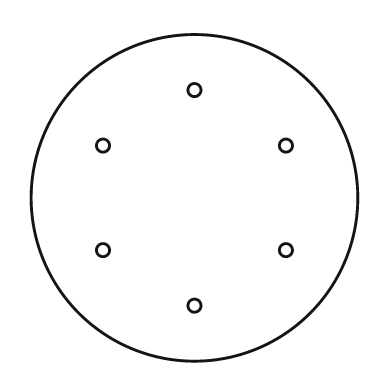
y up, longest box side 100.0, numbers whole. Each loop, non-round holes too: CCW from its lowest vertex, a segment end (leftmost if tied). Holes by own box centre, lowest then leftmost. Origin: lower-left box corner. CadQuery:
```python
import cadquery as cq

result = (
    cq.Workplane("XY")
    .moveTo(50.0, 50.0)
    .circle(50.0)
    .moveTo(50.0, 17.0)
    .circle(2.0)
    .moveTo(22.0, 34.0)
    .circle(2.0)
    .moveTo(78.0, 34.0)
    .circle(2.0)
    .moveTo(22.0, 66.0)
    .circle(2.0)
    .moveTo(78.0, 66.0)
    .circle(2.0)
    .moveTo(50.0, 83.0)
    .circle(2.0)
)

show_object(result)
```